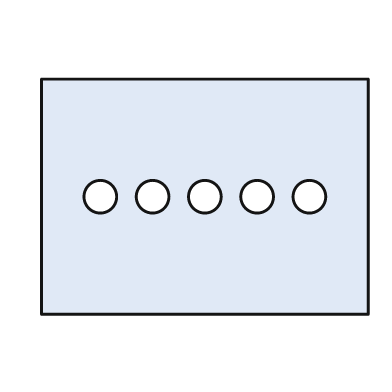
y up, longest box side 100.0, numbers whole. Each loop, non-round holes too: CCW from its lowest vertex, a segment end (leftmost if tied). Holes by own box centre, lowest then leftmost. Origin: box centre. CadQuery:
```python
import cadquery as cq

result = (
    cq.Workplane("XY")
    .moveTo(-50.0, -36.0)
    .lineTo(50.0, -36.0)
    .lineTo(50.0, 36.0)
    .lineTo(-50.0, 36.0)
    .close()
    .moveTo(-32.0, 0.0)
    .circle(5.0)
    .moveTo(-16.0, 0.0)
    .circle(5.0)
    .moveTo(0.0, 0.0)
    .circle(5.0)
    .moveTo(16.0, 0.0)
    .circle(5.0)
    .moveTo(32.0, 0.0)
    .circle(5.0)
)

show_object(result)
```